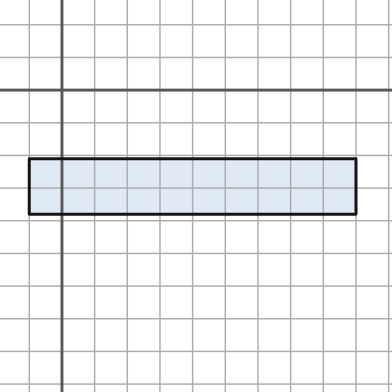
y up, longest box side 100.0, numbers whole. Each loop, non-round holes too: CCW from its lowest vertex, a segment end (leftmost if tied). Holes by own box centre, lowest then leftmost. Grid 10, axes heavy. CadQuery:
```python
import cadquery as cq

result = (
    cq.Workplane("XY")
    .moveTo(-10.0, -38.0)
    .lineTo(90.0, -38.0)
    .lineTo(90.0, -21.0)
    .lineTo(-10.0, -21.0)
    .close()
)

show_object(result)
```